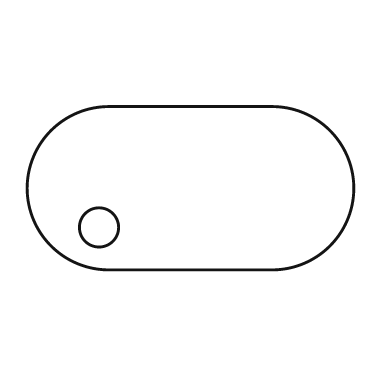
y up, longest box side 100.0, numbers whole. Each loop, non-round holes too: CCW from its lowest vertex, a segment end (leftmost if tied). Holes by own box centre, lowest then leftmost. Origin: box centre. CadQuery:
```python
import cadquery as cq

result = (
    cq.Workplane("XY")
    .moveTo(-25.0, -25.0)
    .lineTo(25.0, -25.0)
    .threePointArc((50.0, 0.0), (25.0, 25.0))
    .lineTo(-25.0, 25.0)
    .threePointArc((-50.0, 0.0), (-25.0, -25.0))
    .close()
    .moveTo(-28.0, -12.0)
    .circle(6.0)
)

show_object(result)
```